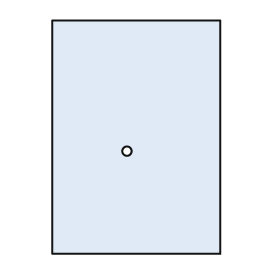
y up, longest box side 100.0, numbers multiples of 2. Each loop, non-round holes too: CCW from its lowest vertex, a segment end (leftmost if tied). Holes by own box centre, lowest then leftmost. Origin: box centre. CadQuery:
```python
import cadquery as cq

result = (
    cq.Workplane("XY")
    .moveTo(-36.0, -50.0)
    .lineTo(36.0, -50.0)
    .lineTo(36.0, 50.0)
    .lineTo(-36.0, 50.0)
    .close()
    .moveTo(-4.0, -6.0)
    .circle(2.0)
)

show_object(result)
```